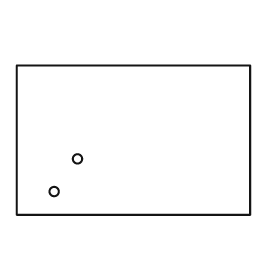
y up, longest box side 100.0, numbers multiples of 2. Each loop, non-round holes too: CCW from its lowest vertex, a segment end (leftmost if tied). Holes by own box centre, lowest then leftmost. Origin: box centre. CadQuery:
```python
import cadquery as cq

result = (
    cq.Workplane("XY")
    .moveTo(-50.0, -32.0)
    .lineTo(50.0, -32.0)
    .lineTo(50.0, 32.0)
    .lineTo(-50.0, 32.0)
    .close()
    .moveTo(-34.0, -22.0)
    .circle(2.0)
    .moveTo(-24.0, -8.0)
    .circle(2.0)
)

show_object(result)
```